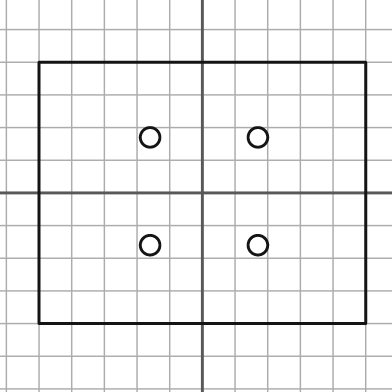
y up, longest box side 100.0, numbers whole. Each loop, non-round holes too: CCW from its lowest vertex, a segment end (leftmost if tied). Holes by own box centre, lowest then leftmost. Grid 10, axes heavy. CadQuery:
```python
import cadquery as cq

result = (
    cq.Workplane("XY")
    .moveTo(-50.0, -40.0)
    .lineTo(50.0, -40.0)
    .lineTo(50.0, 40.0)
    .lineTo(-50.0, 40.0)
    .close()
    .moveTo(-16.0, -16.0)
    .circle(3.0)
    .moveTo(17.0, -16.0)
    .circle(3.0)
    .moveTo(-16.0, 17.0)
    .circle(3.0)
    .moveTo(17.0, 17.0)
    .circle(3.0)
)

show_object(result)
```